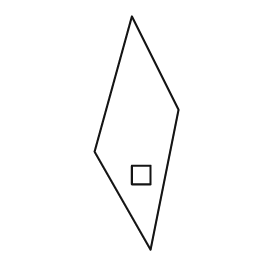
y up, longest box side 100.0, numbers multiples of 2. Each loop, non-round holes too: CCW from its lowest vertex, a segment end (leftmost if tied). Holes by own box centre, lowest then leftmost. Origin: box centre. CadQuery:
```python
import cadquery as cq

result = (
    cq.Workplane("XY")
    .moveTo(6.0, -50.0)
    .lineTo(18.0, 10.0)
    .lineTo(-2.0, 50.0)
    .lineTo(-18.0, -8.0)
    .close()
    .moveTo(-2.0, -22.0)
    .lineTo(6.0, -22.0)
    .lineTo(6.0, -14.0)
    .lineTo(-2.0, -14.0)
    .close()
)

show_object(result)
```